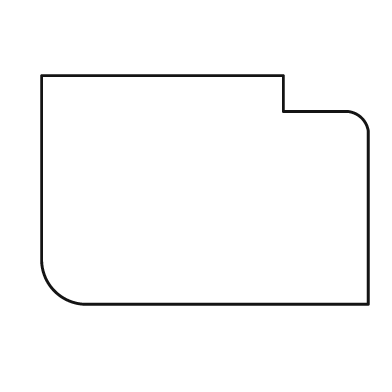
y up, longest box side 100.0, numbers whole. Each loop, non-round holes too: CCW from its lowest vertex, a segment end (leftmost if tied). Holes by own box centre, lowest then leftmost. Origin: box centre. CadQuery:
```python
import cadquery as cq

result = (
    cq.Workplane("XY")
    .moveTo(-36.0, -35.0)
    .lineTo(50.0, -35.0)
    .lineTo(50.0, 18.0)
    .threePointArc((48.0, 22.0), (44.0, 24.0))
    .lineTo(24.0, 24.0)
    .lineTo(24.0, 35.0)
    .lineTo(-50.0, 35.0)
    .lineTo(-50.0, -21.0)
    .threePointArc((-46.0, -31.0), (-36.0, -35.0))
    .close()
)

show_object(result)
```